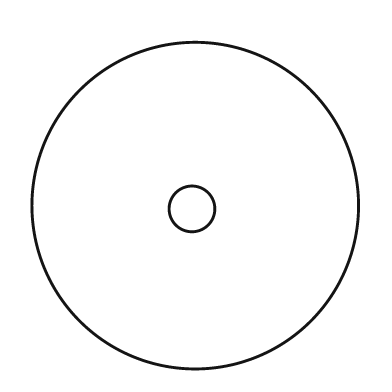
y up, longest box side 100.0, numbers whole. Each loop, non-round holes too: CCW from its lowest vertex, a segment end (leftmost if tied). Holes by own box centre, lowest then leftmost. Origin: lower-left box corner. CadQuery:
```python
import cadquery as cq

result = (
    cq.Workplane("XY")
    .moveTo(50.0, 50.0)
    .circle(50.0)
    .moveTo(49.0, 49.0)
    .circle(7.0)
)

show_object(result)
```